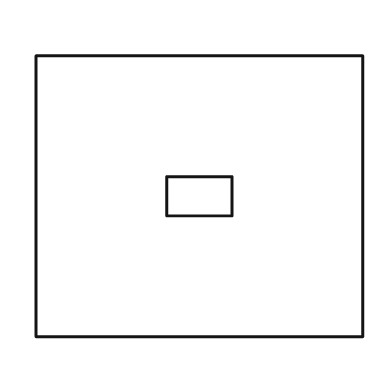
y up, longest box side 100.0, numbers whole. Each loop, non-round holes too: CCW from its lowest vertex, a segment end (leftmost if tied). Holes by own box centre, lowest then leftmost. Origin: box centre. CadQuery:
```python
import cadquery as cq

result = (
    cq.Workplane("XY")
    .moveTo(-50.0, -43.0)
    .lineTo(50.0, -43.0)
    .lineTo(50.0, 43.0)
    .lineTo(-50.0, 43.0)
    .close()
    .moveTo(-10.0, -6.0)
    .lineTo(10.0, -6.0)
    .lineTo(10.0, 6.0)
    .lineTo(-10.0, 6.0)
    .close()
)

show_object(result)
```